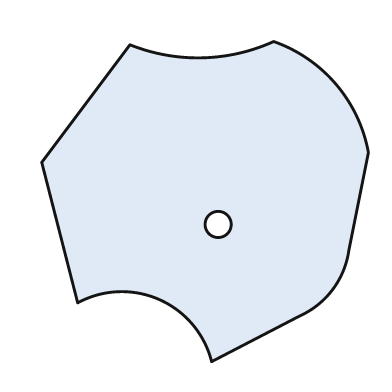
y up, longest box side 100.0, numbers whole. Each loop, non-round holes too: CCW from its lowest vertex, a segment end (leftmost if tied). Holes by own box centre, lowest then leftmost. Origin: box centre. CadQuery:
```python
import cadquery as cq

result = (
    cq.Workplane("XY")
    .moveTo(2.0, -49.0)
    .lineTo(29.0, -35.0)
    .threePointArc((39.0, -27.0), (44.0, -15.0))
    .lineTo(50.0, 15.0)
    .threePointArc((40.0, 36.0), (21.0, 49.0))
    .threePointArc((-1.0, 44.0), (-23.0, 48.0))
    .lineTo(-50.0, 12.0)
    .lineTo(-39.0, -31.0)
    .threePointArc((-14.0, -30.0), (2.0, -49.0))
    .close()
    .moveTo(4.0, -7.0)
    .circle(4.0)
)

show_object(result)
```